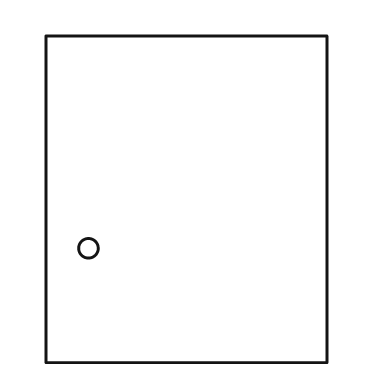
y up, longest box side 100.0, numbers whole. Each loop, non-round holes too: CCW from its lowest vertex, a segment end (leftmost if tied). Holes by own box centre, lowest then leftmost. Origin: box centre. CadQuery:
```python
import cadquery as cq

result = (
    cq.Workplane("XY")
    .moveTo(-43.0, -50.0)
    .lineTo(43.0, -50.0)
    .lineTo(43.0, 50.0)
    .lineTo(-43.0, 50.0)
    .close()
    .moveTo(-30.0, -15.0)
    .circle(3.0)
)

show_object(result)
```